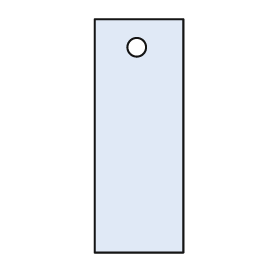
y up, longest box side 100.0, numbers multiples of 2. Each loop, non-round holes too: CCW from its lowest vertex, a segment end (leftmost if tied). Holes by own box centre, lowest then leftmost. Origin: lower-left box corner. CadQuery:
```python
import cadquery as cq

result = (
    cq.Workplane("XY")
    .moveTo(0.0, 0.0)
    .lineTo(38.0, 0.0)
    .lineTo(38.0, 100.0)
    .lineTo(0.0, 100.0)
    .close()
    .moveTo(18.0, 88.0)
    .circle(4.0)
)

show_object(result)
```